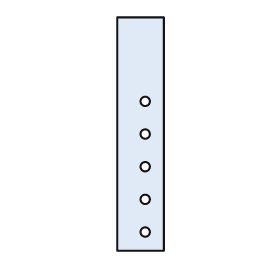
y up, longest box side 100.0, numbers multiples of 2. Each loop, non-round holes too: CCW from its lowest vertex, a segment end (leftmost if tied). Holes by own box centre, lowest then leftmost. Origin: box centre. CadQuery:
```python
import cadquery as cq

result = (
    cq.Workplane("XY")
    .moveTo(-10.0, -50.0)
    .lineTo(10.0, -50.0)
    .lineTo(10.0, 50.0)
    .lineTo(-10.0, 50.0)
    .close()
    .moveTo(2.0, -42.0)
    .circle(2.0)
    .moveTo(2.0, -28.0)
    .circle(2.0)
    .moveTo(2.0, -14.0)
    .circle(2.0)
    .moveTo(2.0, 0.0)
    .circle(2.0)
    .moveTo(2.0, 14.0)
    .circle(2.0)
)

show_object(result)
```